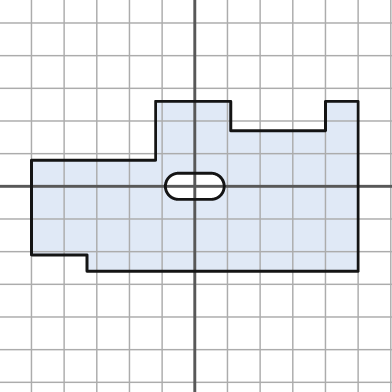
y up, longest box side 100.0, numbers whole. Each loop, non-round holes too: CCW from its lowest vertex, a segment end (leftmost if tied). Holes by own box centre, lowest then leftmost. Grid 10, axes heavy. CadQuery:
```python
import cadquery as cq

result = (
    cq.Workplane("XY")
    .moveTo(-33.0, -26.0)
    .lineTo(50.0, -26.0)
    .lineTo(50.0, 26.0)
    .lineTo(40.0, 26.0)
    .lineTo(40.0, 17.0)
    .lineTo(11.0, 17.0)
    .lineTo(11.0, 26.0)
    .lineTo(-12.0, 26.0)
    .lineTo(-12.0, 8.0)
    .lineTo(-50.0, 8.0)
    .lineTo(-50.0, -21.0)
    .lineTo(-33.0, -21.0)
    .close()
    .moveTo(-5.0, -4.0)
    .lineTo(5.0, -4.0)
    .threePointArc((9.0, 0.0), (5.0, 4.0))
    .lineTo(-5.0, 4.0)
    .threePointArc((-9.0, 0.0), (-5.0, -4.0))
    .close()
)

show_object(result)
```